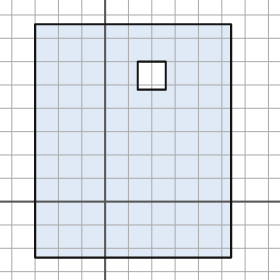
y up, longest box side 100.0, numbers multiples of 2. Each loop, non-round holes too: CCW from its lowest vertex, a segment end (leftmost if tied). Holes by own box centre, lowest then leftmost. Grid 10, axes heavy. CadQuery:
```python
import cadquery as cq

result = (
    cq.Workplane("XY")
    .moveTo(-30.0, -24.0)
    .lineTo(54.0, -24.0)
    .lineTo(54.0, 76.0)
    .lineTo(-30.0, 76.0)
    .close()
    .moveTo(14.0, 48.0)
    .lineTo(26.0, 48.0)
    .lineTo(26.0, 60.0)
    .lineTo(14.0, 60.0)
    .close()
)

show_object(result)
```